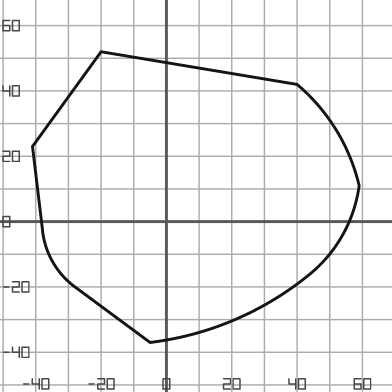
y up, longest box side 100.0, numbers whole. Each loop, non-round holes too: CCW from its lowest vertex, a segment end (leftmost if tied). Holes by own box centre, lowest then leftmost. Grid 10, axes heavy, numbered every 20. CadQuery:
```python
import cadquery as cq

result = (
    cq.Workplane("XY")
    .moveTo(-5.0, -37.0)
    .threePointArc((21.0, -30.0), (44.0, -16.0))
    .threePointArc((54.0, -4.0), (59.0, 11.0))
    .threePointArc((52.0, 28.0), (40.0, 42.0))
    .lineTo(-20.0, 52.0)
    .lineTo(-41.0, 23.0)
    .lineTo(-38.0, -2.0)
    .threePointArc((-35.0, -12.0), (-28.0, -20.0))
    .close()
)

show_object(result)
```